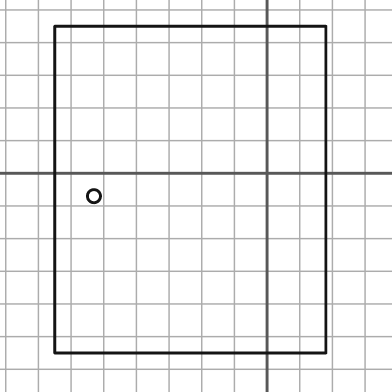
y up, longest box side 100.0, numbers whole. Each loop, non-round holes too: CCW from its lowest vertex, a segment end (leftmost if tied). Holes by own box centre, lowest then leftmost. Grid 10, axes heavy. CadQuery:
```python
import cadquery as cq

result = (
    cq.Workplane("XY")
    .moveTo(-65.0, -55.0)
    .lineTo(18.0, -55.0)
    .lineTo(18.0, 45.0)
    .lineTo(-65.0, 45.0)
    .close()
    .moveTo(-53.0, -7.0)
    .circle(2.0)
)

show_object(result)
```